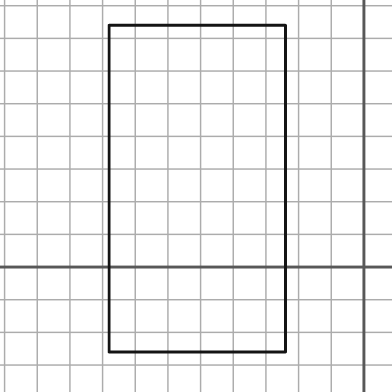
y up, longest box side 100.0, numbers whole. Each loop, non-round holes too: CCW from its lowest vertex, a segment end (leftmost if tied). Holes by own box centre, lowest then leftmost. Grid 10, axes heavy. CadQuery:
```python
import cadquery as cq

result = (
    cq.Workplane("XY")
    .moveTo(-78.0, -26.0)
    .lineTo(-24.0, -26.0)
    .lineTo(-24.0, 74.0)
    .lineTo(-78.0, 74.0)
    .close()
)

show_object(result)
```